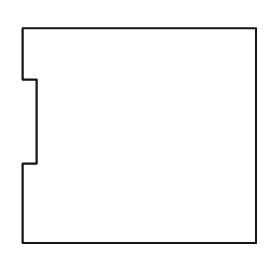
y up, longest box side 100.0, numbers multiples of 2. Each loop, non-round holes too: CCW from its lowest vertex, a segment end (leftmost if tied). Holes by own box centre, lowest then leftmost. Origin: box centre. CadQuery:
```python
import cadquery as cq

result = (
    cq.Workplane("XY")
    .moveTo(-50.0, -46.0)
    .lineTo(50.0, -46.0)
    .lineTo(50.0, 46.0)
    .lineTo(-50.0, 46.0)
    .lineTo(-50.0, 24.0)
    .lineTo(-44.0, 24.0)
    .lineTo(-44.0, -12.0)
    .lineTo(-50.0, -12.0)
    .close()
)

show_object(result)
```